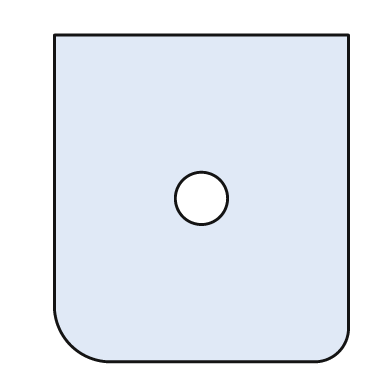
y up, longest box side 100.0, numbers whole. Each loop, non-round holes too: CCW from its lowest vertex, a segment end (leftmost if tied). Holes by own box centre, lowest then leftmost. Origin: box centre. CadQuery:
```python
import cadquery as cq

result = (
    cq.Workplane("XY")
    .moveTo(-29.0, -50.0)
    .lineTo(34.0, -50.0)
    .threePointArc((42.0, -47.0), (45.0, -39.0))
    .lineTo(45.0, 50.0)
    .lineTo(-45.0, 50.0)
    .lineTo(-45.0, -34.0)
    .threePointArc((-40.0, -45.0), (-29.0, -50.0))
    .close()
    .moveTo(0.0, 0.0)
    .circle(8.0)
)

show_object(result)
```